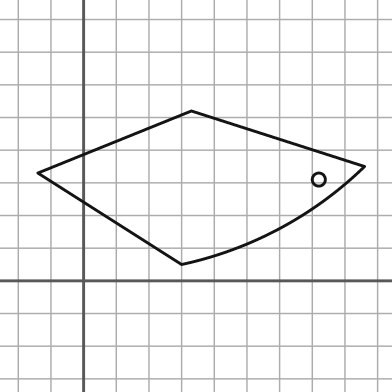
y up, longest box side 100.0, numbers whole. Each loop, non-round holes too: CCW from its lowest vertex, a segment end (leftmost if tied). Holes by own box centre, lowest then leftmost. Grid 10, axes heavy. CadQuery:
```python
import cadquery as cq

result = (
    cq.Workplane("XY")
    .moveTo(30.0, 5.0)
    .threePointArc((60.0, 16.0), (86.0, 35.0))
    .lineTo(33.0, 52.0)
    .lineTo(-14.0, 33.0)
    .close()
    .moveTo(72.0, 31.0)
    .circle(2.0)
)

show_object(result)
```